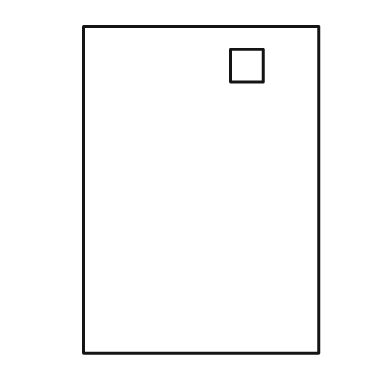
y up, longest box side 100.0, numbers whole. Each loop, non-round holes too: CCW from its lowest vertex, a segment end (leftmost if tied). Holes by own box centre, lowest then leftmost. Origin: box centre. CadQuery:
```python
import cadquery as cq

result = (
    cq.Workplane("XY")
    .moveTo(-36.0, -50.0)
    .lineTo(36.0, -50.0)
    .lineTo(36.0, 50.0)
    .lineTo(-36.0, 50.0)
    .close()
    .moveTo(9.0, 33.0)
    .lineTo(19.0, 33.0)
    .lineTo(19.0, 43.0)
    .lineTo(9.0, 43.0)
    .close()
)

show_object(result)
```